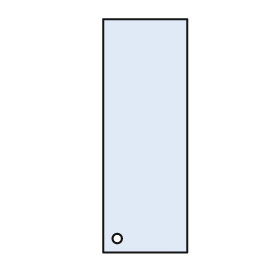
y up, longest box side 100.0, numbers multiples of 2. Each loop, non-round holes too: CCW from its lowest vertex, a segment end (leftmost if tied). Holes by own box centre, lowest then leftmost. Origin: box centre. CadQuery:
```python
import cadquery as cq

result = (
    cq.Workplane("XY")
    .moveTo(-18.0, -50.0)
    .lineTo(18.0, -50.0)
    .lineTo(18.0, 50.0)
    .lineTo(-18.0, 50.0)
    .close()
    .moveTo(-12.0, -44.0)
    .circle(2.0)
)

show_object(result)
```